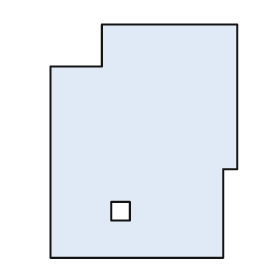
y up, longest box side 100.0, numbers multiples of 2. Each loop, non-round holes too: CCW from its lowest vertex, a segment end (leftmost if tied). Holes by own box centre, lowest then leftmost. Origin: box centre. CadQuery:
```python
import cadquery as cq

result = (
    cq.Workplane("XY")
    .moveTo(-40.0, -50.0)
    .lineTo(34.0, -50.0)
    .lineTo(34.0, -12.0)
    .lineTo(40.0, -12.0)
    .lineTo(40.0, 50.0)
    .lineTo(-18.0, 50.0)
    .lineTo(-18.0, 32.0)
    .lineTo(-40.0, 32.0)
    .close()
    .moveTo(-14.0, -34.0)
    .lineTo(-6.0, -34.0)
    .lineTo(-6.0, -26.0)
    .lineTo(-14.0, -26.0)
    .close()
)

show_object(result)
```